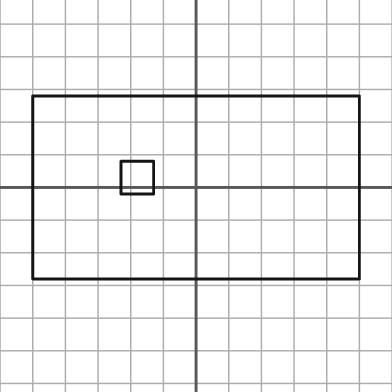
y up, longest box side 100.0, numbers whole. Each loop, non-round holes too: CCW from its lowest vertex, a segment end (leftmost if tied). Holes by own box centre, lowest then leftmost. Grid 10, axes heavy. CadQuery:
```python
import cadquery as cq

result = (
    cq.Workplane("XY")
    .moveTo(-50.0, -28.0)
    .lineTo(50.0, -28.0)
    .lineTo(50.0, 28.0)
    .lineTo(-50.0, 28.0)
    .close()
    .moveTo(-23.0, -2.0)
    .lineTo(-13.0, -2.0)
    .lineTo(-13.0, 8.0)
    .lineTo(-23.0, 8.0)
    .close()
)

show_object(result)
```